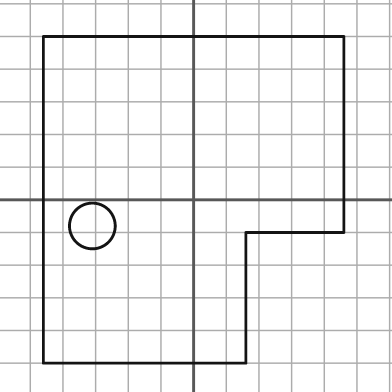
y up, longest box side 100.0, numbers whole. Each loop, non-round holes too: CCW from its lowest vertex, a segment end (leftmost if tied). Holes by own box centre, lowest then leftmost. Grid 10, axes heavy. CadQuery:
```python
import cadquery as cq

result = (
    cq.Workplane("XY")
    .moveTo(-46.0, -50.0)
    .lineTo(16.0, -50.0)
    .lineTo(16.0, -10.0)
    .lineTo(46.0, -10.0)
    .lineTo(46.0, 50.0)
    .lineTo(-46.0, 50.0)
    .close()
    .moveTo(-31.0, -8.0)
    .circle(7.0)
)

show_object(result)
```